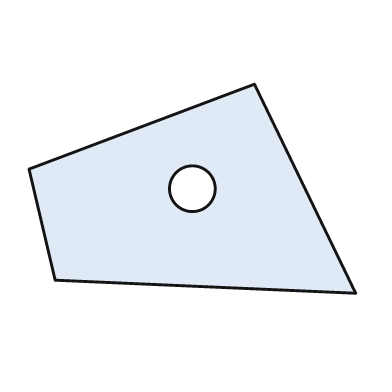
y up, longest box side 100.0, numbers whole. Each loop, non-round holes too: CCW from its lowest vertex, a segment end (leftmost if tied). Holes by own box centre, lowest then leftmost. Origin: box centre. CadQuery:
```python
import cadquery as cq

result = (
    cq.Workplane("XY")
    .moveTo(50.0, -32.0)
    .lineTo(19.0, 32.0)
    .lineTo(-50.0, 6.0)
    .lineTo(-42.0, -28.0)
    .close()
    .moveTo(0.0, 0.0)
    .circle(7.0)
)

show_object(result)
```